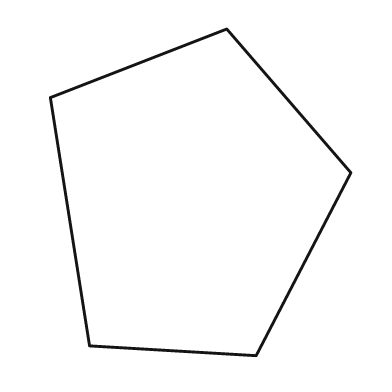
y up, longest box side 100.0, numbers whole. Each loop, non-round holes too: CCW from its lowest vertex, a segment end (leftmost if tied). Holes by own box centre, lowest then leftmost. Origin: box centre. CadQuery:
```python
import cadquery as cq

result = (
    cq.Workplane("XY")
    .moveTo(17.0, -50.0)
    .lineTo(46.0, 6.0)
    .lineTo(8.0, 50.0)
    .lineTo(-46.0, 29.0)
    .lineTo(-34.0, -47.0)
    .close()
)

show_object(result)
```